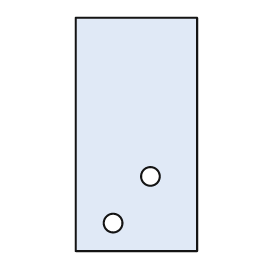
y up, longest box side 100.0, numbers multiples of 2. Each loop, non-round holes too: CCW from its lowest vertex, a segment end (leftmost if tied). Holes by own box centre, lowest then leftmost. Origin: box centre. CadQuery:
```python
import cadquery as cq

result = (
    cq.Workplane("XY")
    .moveTo(-26.0, -50.0)
    .lineTo(26.0, -50.0)
    .lineTo(26.0, 50.0)
    .lineTo(-26.0, 50.0)
    .close()
    .moveTo(-10.0, -38.0)
    .circle(4.0)
    .moveTo(6.0, -18.0)
    .circle(4.0)
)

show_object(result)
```